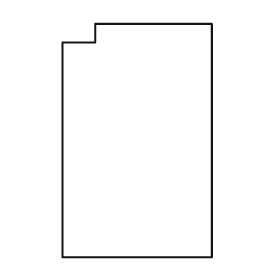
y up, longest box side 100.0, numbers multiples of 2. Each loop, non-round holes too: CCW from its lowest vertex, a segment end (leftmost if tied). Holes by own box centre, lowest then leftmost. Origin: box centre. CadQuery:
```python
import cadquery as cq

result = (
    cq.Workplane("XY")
    .moveTo(-32.0, -50.0)
    .lineTo(32.0, -50.0)
    .lineTo(32.0, 50.0)
    .lineTo(-18.0, 50.0)
    .lineTo(-18.0, 42.0)
    .lineTo(-32.0, 42.0)
    .close()
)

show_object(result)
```